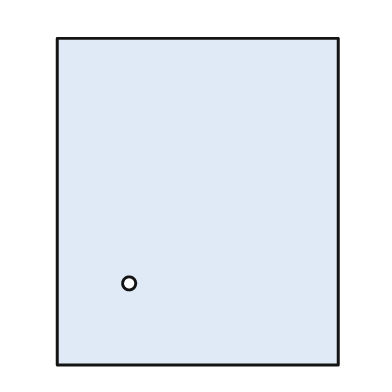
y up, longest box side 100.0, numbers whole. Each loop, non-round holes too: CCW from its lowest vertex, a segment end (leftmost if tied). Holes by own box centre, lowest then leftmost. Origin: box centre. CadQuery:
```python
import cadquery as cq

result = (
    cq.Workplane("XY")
    .moveTo(-43.0, -50.0)
    .lineTo(43.0, -50.0)
    .lineTo(43.0, 50.0)
    .lineTo(-43.0, 50.0)
    .close()
    .moveTo(-21.0, -25.0)
    .circle(2.0)
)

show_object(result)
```